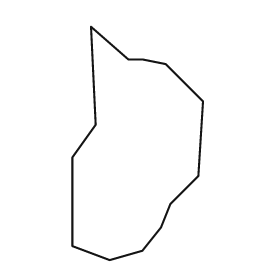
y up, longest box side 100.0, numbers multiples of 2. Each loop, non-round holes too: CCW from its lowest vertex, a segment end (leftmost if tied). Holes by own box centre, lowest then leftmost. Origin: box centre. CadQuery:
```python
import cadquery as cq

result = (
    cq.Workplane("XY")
    .moveTo(-12.0, -50.0)
    .lineTo(2.0, -46.0)
    .lineTo(10.0, -36.0)
    .lineTo(14.0, -26.0)
    .lineTo(26.0, -14.0)
    .lineTo(28.0, 18.0)
    .lineTo(12.0, 34.0)
    .lineTo(2.0, 36.0)
    .lineTo(-4.0, 36.0)
    .lineTo(-20.0, 50.0)
    .lineTo(-18.0, 8.0)
    .lineTo(-28.0, -6.0)
    .lineTo(-28.0, -44.0)
    .close()
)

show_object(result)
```